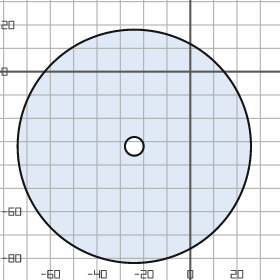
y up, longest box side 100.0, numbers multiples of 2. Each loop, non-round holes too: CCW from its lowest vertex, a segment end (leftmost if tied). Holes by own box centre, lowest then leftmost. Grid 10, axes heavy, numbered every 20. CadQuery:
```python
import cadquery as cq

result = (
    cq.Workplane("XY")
    .moveTo(-24.0, -32.0)
    .circle(50.0)
    .moveTo(-24.0, -32.0)
    .circle(4.0)
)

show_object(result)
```